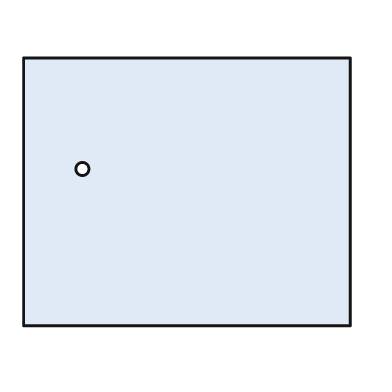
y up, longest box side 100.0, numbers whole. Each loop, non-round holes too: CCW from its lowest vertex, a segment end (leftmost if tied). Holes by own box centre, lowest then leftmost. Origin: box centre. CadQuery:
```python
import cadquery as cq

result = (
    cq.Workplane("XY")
    .moveTo(-50.0, -41.0)
    .lineTo(50.0, -41.0)
    .lineTo(50.0, 41.0)
    .lineTo(-50.0, 41.0)
    .close()
    .moveTo(-32.0, 7.0)
    .circle(2.0)
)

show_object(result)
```